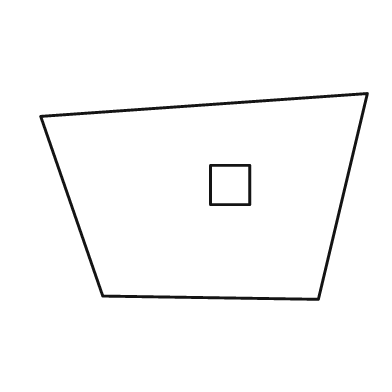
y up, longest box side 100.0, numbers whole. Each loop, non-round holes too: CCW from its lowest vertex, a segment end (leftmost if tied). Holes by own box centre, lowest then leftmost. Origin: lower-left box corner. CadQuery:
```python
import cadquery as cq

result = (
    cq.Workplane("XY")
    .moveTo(85.0, 0.0)
    .lineTo(100.0, 63.0)
    .lineTo(0.0, 56.0)
    .lineTo(19.0, 1.0)
    .close()
    .moveTo(52.0, 29.0)
    .lineTo(64.0, 29.0)
    .lineTo(64.0, 41.0)
    .lineTo(52.0, 41.0)
    .close()
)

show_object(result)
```